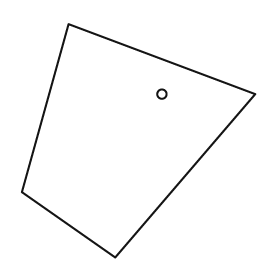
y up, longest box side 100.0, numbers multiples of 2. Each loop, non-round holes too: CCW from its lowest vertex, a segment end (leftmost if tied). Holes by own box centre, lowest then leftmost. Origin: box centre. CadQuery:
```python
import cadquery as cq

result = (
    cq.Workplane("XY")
    .moveTo(-10.0, -50.0)
    .lineTo(50.0, 20.0)
    .lineTo(-30.0, 50.0)
    .lineTo(-50.0, -22.0)
    .close()
    .moveTo(10.0, 20.0)
    .circle(2.0)
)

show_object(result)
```